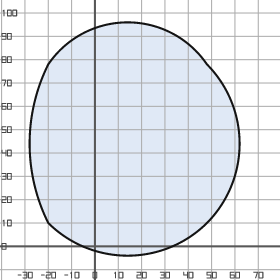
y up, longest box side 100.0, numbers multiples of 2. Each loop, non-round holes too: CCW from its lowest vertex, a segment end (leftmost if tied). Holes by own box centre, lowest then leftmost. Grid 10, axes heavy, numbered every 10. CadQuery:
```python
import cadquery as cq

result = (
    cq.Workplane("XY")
    .moveTo(-20.0, 10.0)
    .threePointArc((14.0, -4.0), (48.0, 10.0))
    .threePointArc((62.0, 44.0), (48.0, 78.0))
    .threePointArc((14.0, 96.0), (-20.0, 78.0))
    .threePointArc((-28.0, 44.0), (-20.0, 10.0))
    .close()
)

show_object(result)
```